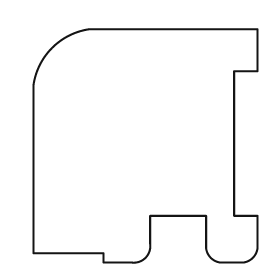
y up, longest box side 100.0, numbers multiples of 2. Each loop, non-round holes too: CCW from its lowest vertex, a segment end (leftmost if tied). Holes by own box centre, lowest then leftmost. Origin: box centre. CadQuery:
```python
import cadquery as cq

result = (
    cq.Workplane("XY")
    .moveTo(-18.0, -50.0)
    .lineTo(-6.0, -50.0)
    .threePointArc((0.0, -48.0), (2.0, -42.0))
    .lineTo(2.0, -30.0)
    .lineTo(26.0, -30.0)
    .lineTo(26.0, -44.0)
    .threePointArc((28.0, -48.0), (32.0, -50.0))
    .lineTo(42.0, -50.0)
    .threePointArc((46.0, -48.0), (48.0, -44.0))
    .lineTo(48.0, -30.0)
    .lineTo(38.0, -30.0)
    .lineTo(38.0, 32.0)
    .lineTo(48.0, 32.0)
    .lineTo(48.0, 50.0)
    .lineTo(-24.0, 50.0)
    .threePointArc((-40.0, 42.0), (-48.0, 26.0))
    .lineTo(-48.0, -46.0)
    .lineTo(-18.0, -46.0)
    .close()
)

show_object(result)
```